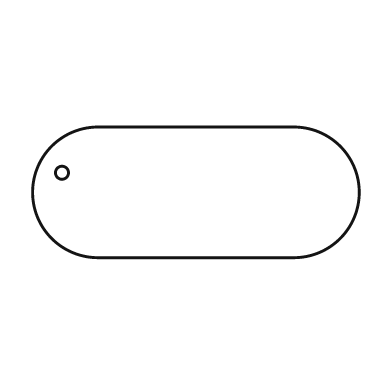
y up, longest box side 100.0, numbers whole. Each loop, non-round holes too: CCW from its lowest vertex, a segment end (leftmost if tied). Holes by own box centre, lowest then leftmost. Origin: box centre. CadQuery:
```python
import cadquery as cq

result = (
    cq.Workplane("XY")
    .moveTo(-30.0, -20.0)
    .lineTo(30.0, -20.0)
    .threePointArc((50.0, 0.0), (30.0, 20.0))
    .lineTo(-30.0, 20.0)
    .threePointArc((-50.0, 0.0), (-30.0, -20.0))
    .close()
    .moveTo(-41.0, 6.0)
    .circle(2.0)
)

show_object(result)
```